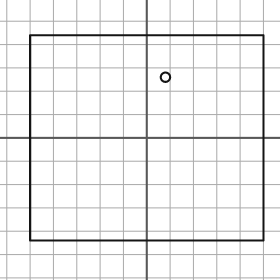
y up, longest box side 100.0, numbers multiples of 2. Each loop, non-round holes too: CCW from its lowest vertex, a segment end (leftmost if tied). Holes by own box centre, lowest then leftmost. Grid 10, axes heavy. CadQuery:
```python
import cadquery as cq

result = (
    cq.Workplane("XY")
    .moveTo(-50.0, -44.0)
    .lineTo(50.0, -44.0)
    .lineTo(50.0, 44.0)
    .lineTo(-50.0, 44.0)
    .close()
    .moveTo(8.0, 26.0)
    .circle(2.0)
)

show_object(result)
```